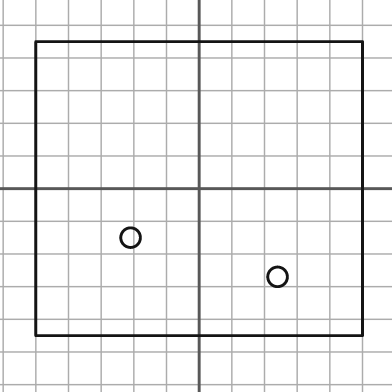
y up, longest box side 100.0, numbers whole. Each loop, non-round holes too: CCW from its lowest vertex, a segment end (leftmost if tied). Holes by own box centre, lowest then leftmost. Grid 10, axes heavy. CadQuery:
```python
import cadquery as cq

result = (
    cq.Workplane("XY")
    .moveTo(-50.0, -45.0)
    .lineTo(50.0, -45.0)
    .lineTo(50.0, 45.0)
    .lineTo(-50.0, 45.0)
    .close()
    .moveTo(24.0, -27.0)
    .circle(3.0)
    .moveTo(-21.0, -15.0)
    .circle(3.0)
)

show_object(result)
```